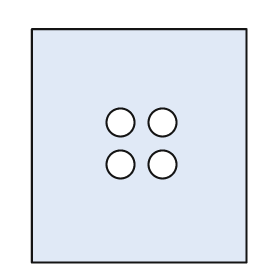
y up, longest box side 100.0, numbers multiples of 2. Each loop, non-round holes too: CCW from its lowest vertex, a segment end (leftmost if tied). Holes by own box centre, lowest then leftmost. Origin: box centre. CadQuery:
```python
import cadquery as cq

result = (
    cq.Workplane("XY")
    .moveTo(-46.0, -50.0)
    .lineTo(46.0, -50.0)
    .lineTo(46.0, 50.0)
    .lineTo(-46.0, 50.0)
    .close()
    .moveTo(-8.0, -8.0)
    .circle(6.0)
    .moveTo(10.0, -8.0)
    .circle(6.0)
    .moveTo(-8.0, 10.0)
    .circle(6.0)
    .moveTo(10.0, 10.0)
    .circle(6.0)
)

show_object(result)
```